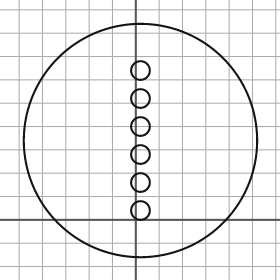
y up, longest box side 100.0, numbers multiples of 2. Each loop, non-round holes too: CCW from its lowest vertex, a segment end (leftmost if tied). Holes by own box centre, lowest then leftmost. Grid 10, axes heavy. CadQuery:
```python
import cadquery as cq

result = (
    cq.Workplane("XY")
    .moveTo(2.0, 34.0)
    .circle(50.0)
    .moveTo(2.0, 4.0)
    .circle(4.0)
    .moveTo(2.0, 16.0)
    .circle(4.0)
    .moveTo(2.0, 28.0)
    .circle(4.0)
    .moveTo(2.0, 40.0)
    .circle(4.0)
    .moveTo(2.0, 52.0)
    .circle(4.0)
    .moveTo(2.0, 64.0)
    .circle(4.0)
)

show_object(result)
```